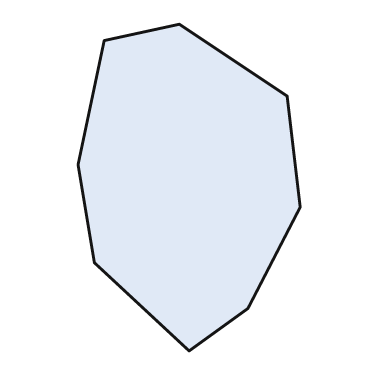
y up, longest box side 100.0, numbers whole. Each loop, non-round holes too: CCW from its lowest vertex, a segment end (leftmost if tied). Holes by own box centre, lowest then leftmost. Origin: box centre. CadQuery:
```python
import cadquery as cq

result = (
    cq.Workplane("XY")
    .moveTo(0.0, -50.0)
    .lineTo(18.0, -37.0)
    .lineTo(34.0, -6.0)
    .lineTo(30.0, 28.0)
    .lineTo(-3.0, 50.0)
    .lineTo(-26.0, 45.0)
    .lineTo(-34.0, 7.0)
    .lineTo(-29.0, -23.0)
    .close()
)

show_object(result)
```